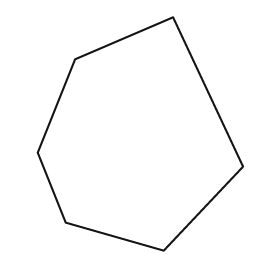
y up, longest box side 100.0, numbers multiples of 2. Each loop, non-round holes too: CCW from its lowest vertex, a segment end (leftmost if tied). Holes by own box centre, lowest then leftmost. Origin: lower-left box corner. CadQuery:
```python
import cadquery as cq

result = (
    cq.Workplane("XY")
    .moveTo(54.0, 0.0)
    .lineTo(88.0, 36.0)
    .lineTo(58.0, 100.0)
    .lineTo(16.0, 82.0)
    .lineTo(0.0, 42.0)
    .lineTo(12.0, 12.0)
    .close()
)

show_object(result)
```